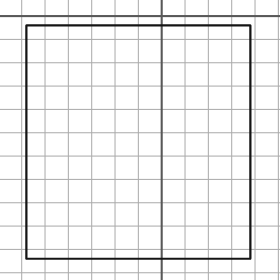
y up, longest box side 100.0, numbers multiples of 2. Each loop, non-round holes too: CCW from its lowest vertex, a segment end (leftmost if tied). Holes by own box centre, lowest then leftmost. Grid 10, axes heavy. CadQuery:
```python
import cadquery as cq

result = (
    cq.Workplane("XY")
    .moveTo(-58.0, -104.0)
    .lineTo(38.0, -104.0)
    .lineTo(38.0, -4.0)
    .lineTo(-58.0, -4.0)
    .close()
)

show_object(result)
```